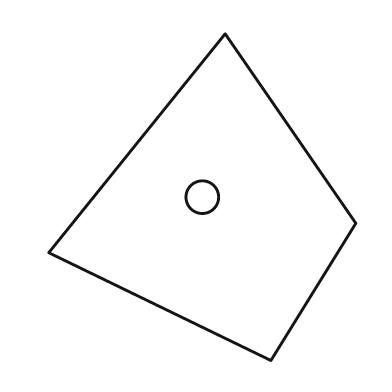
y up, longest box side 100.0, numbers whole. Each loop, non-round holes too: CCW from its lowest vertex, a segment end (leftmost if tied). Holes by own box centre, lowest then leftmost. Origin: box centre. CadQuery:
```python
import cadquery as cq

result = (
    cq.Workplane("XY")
    .moveTo(21.0, -50.0)
    .lineTo(47.0, -8.0)
    .lineTo(7.0, 50.0)
    .lineTo(-47.0, -17.0)
    .close()
    .moveTo(0.0, 0.0)
    .circle(5.0)
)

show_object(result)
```